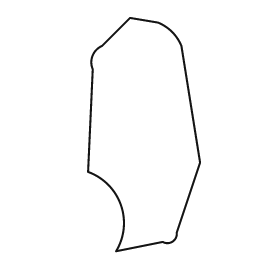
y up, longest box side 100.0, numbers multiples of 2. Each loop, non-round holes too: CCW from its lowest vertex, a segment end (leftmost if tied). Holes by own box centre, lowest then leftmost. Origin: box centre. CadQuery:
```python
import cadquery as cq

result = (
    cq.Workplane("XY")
    .moveTo(-12.0, -50.0)
    .lineTo(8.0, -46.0)
    .threePointArc((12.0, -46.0), (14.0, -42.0))
    .lineTo(24.0, -12.0)
    .lineTo(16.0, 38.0)
    .threePointArc((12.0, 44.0), (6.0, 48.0))
    .lineTo(-6.0, 50.0)
    .lineTo(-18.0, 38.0)
    .threePointArc((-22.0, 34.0), (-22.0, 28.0))
    .lineTo(-24.0, -16.0)
    .threePointArc((-10.0, -30.0), (-12.0, -50.0))
    .close()
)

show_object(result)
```